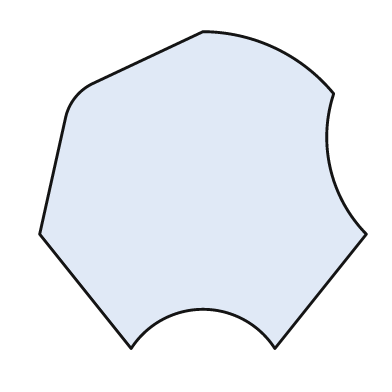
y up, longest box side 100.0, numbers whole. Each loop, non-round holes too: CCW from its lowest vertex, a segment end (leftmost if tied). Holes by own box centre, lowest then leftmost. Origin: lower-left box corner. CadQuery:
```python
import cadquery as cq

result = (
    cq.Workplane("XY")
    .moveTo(28.0, 0.0)
    .threePointArc((50.0, 12.0), (72.0, 0.0))
    .lineTo(100.0, 35.0)
    .threePointArc((89.0, 55.0), (90.0, 78.0))
    .threePointArc((72.0, 92.0), (50.0, 97.0))
    .lineTo(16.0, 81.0)
    .threePointArc((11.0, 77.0), (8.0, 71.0))
    .lineTo(0.0, 35.0)
    .close()
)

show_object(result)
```